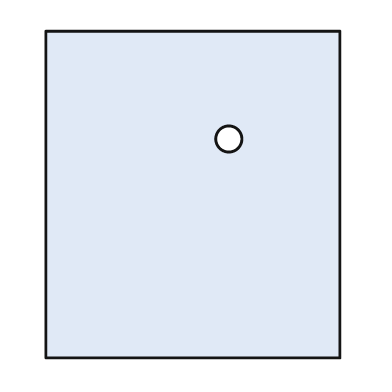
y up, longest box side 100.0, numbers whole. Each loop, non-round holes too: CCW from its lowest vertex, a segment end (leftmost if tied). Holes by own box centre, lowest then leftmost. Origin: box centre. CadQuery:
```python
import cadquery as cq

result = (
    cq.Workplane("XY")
    .moveTo(-45.0, -50.0)
    .lineTo(45.0, -50.0)
    .lineTo(45.0, 50.0)
    .lineTo(-45.0, 50.0)
    .close()
    .moveTo(11.0, 17.0)
    .circle(4.0)
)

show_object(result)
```